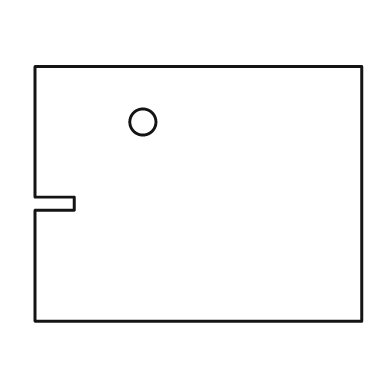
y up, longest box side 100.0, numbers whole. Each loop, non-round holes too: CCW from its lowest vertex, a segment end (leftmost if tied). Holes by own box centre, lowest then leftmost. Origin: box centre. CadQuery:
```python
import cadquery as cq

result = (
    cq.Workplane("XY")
    .moveTo(-50.0, -39.0)
    .lineTo(50.0, -39.0)
    .lineTo(50.0, 39.0)
    .lineTo(-50.0, 39.0)
    .lineTo(-50.0, -1.0)
    .lineTo(-38.0, -1.0)
    .lineTo(-38.0, -5.0)
    .lineTo(-50.0, -5.0)
    .close()
    .moveTo(-17.0, 22.0)
    .circle(4.0)
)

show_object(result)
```